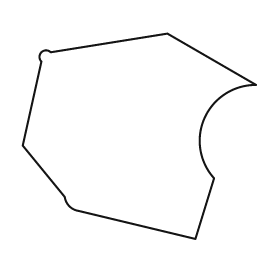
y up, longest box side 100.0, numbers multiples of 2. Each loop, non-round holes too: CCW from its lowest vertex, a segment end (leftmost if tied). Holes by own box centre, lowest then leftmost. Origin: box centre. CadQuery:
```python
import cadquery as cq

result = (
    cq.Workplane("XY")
    .moveTo(24.0, -44.0)
    .lineTo(32.0, -18.0)
    .threePointArc((28.0, 8.0), (50.0, 22.0))
    .lineTo(12.0, 44.0)
    .lineTo(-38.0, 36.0)
    .threePointArc((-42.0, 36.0), (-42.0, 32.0))
    .lineTo(-50.0, -4.0)
    .lineTo(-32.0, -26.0)
    .threePointArc((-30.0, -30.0), (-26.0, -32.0))
    .close()
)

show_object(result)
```